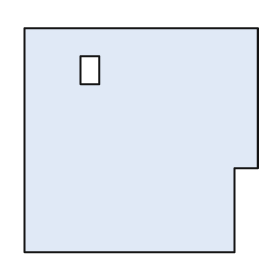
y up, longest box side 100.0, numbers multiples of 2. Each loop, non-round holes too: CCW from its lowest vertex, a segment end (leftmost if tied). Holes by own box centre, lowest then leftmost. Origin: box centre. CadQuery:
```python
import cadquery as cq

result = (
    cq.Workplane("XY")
    .moveTo(-50.0, -48.0)
    .lineTo(40.0, -48.0)
    .lineTo(40.0, -12.0)
    .lineTo(50.0, -12.0)
    .lineTo(50.0, 48.0)
    .lineTo(-50.0, 48.0)
    .close()
    .moveTo(-26.0, 24.0)
    .lineTo(-18.0, 24.0)
    .lineTo(-18.0, 36.0)
    .lineTo(-26.0, 36.0)
    .close()
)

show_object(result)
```